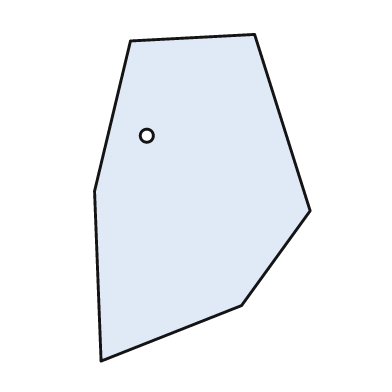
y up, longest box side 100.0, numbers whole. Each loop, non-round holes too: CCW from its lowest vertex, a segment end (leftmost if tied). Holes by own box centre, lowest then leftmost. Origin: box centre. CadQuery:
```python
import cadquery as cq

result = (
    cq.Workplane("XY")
    .moveTo(-31.0, -50.0)
    .lineTo(12.0, -33.0)
    .lineTo(33.0, -4.0)
    .lineTo(16.0, 50.0)
    .lineTo(-22.0, 48.0)
    .lineTo(-33.0, 2.0)
    .close()
    .moveTo(-17.0, 19.0)
    .circle(2.0)
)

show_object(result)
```